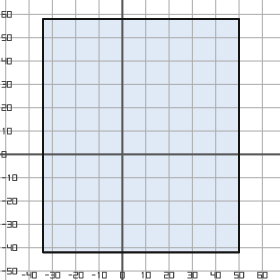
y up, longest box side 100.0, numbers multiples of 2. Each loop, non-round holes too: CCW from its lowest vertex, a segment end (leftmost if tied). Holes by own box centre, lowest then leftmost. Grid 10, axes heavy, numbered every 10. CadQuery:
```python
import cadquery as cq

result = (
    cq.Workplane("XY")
    .moveTo(-34.0, -42.0)
    .lineTo(50.0, -42.0)
    .lineTo(50.0, 58.0)
    .lineTo(-34.0, 58.0)
    .close()
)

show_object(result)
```